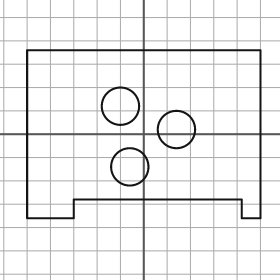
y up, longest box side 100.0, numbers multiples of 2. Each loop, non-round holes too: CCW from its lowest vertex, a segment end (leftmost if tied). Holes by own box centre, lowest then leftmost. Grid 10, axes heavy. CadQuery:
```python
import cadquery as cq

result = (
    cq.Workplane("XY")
    .moveTo(-50.0, -36.0)
    .lineTo(-30.0, -36.0)
    .lineTo(-30.0, -28.0)
    .lineTo(42.0, -28.0)
    .lineTo(42.0, -36.0)
    .lineTo(50.0, -36.0)
    .lineTo(50.0, 36.0)
    .lineTo(-50.0, 36.0)
    .close()
    .moveTo(-6.0, -14.0)
    .circle(8.0)
    .moveTo(14.0, 2.0)
    .circle(8.0)
    .moveTo(-10.0, 12.0)
    .circle(8.0)
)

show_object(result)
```